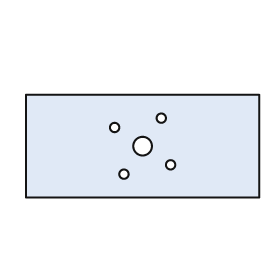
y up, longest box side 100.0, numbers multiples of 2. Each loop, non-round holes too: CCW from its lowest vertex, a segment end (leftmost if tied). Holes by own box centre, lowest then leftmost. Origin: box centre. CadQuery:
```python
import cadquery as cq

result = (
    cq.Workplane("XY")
    .moveTo(-50.0, -22.0)
    .lineTo(50.0, -22.0)
    .lineTo(50.0, 22.0)
    .lineTo(-50.0, 22.0)
    .close()
    .moveTo(-8.0, -12.0)
    .circle(2.0)
    .moveTo(12.0, -8.0)
    .circle(2.0)
    .moveTo(0.0, 0.0)
    .circle(4.0)
    .moveTo(-12.0, 8.0)
    .circle(2.0)
    .moveTo(8.0, 12.0)
    .circle(2.0)
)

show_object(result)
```